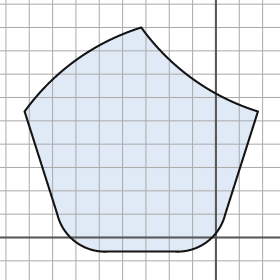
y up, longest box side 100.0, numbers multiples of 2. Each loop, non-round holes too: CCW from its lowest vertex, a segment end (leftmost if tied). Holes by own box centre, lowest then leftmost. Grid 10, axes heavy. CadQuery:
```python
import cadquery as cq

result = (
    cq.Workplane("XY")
    .moveTo(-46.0, -6.0)
    .lineTo(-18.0, -6.0)
    .threePointArc((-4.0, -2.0), (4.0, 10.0))
    .lineTo(18.0, 54.0)
    .threePointArc((-10.0, 68.0), (-32.0, 90.0))
    .threePointArc((-60.0, 76.0), (-82.0, 54.0))
    .lineTo(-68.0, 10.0)
    .threePointArc((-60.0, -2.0), (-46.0, -6.0))
    .close()
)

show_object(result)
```